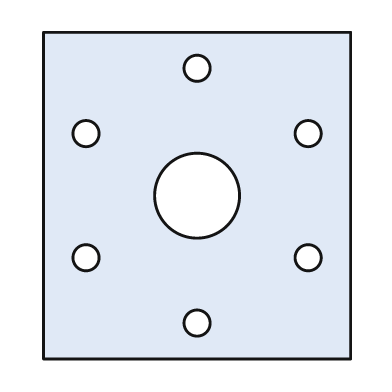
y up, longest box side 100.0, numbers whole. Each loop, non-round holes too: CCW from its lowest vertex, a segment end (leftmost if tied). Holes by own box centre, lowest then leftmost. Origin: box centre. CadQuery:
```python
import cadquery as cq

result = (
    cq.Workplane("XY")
    .moveTo(-47.0, -50.0)
    .lineTo(47.0, -50.0)
    .lineTo(47.0, 50.0)
    .lineTo(-47.0, 50.0)
    .close()
    .moveTo(0.0, -39.0)
    .circle(4.0)
    .moveTo(-34.0, -19.0)
    .circle(4.0)
    .moveTo(34.0, -19.0)
    .circle(4.0)
    .moveTo(0.0, 0.0)
    .circle(13.0)
    .moveTo(-34.0, 19.0)
    .circle(4.0)
    .moveTo(34.0, 19.0)
    .circle(4.0)
    .moveTo(0.0, 39.0)
    .circle(4.0)
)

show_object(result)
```